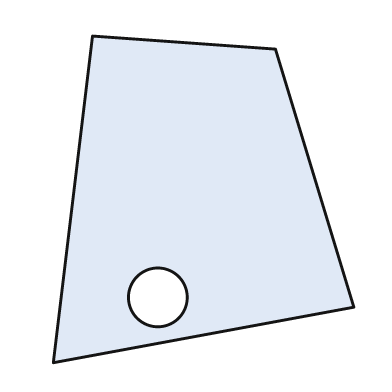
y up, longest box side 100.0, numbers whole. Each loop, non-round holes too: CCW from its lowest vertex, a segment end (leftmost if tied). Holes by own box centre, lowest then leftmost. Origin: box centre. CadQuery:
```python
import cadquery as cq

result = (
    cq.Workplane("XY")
    .moveTo(-46.0, -50.0)
    .lineTo(46.0, -33.0)
    .lineTo(22.0, 46.0)
    .lineTo(-34.0, 50.0)
    .close()
    .moveTo(-14.0, -30.0)
    .circle(9.0)
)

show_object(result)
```